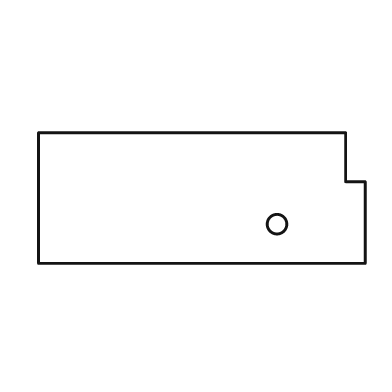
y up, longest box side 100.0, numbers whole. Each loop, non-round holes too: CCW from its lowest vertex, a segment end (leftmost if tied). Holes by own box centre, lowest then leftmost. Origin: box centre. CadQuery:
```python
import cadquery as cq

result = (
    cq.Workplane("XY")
    .moveTo(-50.0, -20.0)
    .lineTo(50.0, -20.0)
    .lineTo(50.0, 5.0)
    .lineTo(44.0, 5.0)
    .lineTo(44.0, 20.0)
    .lineTo(-50.0, 20.0)
    .close()
    .moveTo(23.0, -8.0)
    .circle(3.0)
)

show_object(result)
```